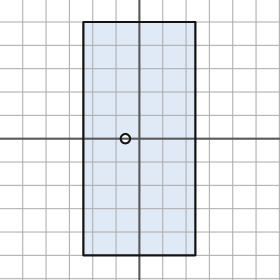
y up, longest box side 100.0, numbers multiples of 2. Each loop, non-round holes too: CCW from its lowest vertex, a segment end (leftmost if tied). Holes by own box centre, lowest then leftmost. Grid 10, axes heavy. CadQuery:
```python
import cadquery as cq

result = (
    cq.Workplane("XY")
    .moveTo(-24.0, -50.0)
    .lineTo(24.0, -50.0)
    .lineTo(24.0, 50.0)
    .lineTo(-24.0, 50.0)
    .close()
    .moveTo(-6.0, 0.0)
    .circle(2.0)
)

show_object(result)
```